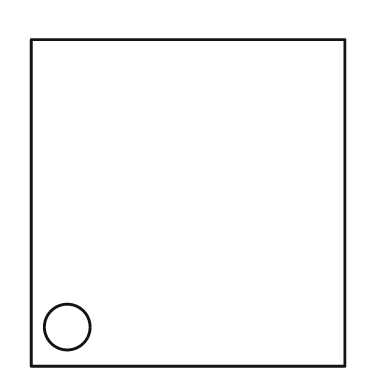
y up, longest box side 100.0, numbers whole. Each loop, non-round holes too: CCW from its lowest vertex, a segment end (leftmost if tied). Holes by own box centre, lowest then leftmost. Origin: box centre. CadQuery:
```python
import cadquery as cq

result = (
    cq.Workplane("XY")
    .moveTo(-48.0, -50.0)
    .lineTo(48.0, -50.0)
    .lineTo(48.0, 50.0)
    .lineTo(-48.0, 50.0)
    .close()
    .moveTo(-37.0, -38.0)
    .circle(7.0)
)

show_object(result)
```